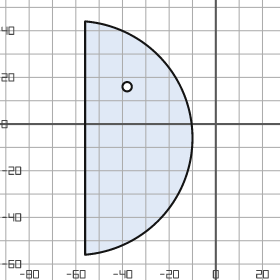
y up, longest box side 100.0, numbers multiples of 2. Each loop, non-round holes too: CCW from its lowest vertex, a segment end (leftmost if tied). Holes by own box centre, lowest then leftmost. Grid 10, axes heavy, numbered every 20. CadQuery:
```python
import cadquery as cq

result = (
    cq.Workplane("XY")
    .moveTo(-56.0, -56.0)
    .threePointArc((-10.0, -6.0), (-56.0, 44.0))
    .close()
    .moveTo(-38.0, 16.0)
    .circle(2.0)
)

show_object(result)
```